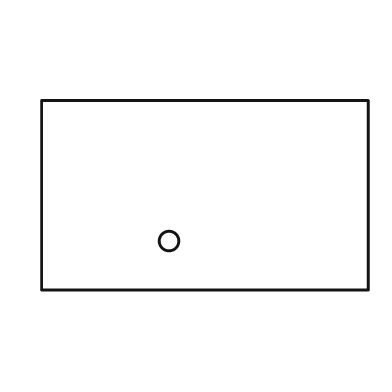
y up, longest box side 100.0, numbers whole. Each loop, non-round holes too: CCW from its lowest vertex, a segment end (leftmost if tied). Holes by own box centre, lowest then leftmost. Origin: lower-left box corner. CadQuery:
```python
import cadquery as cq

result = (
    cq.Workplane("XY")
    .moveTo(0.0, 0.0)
    .lineTo(100.0, 0.0)
    .lineTo(100.0, 58.0)
    .lineTo(0.0, 58.0)
    .close()
    .moveTo(39.0, 15.0)
    .circle(3.0)
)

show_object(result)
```